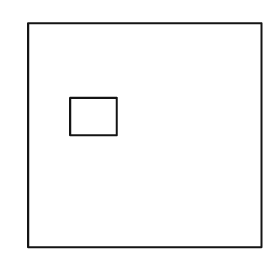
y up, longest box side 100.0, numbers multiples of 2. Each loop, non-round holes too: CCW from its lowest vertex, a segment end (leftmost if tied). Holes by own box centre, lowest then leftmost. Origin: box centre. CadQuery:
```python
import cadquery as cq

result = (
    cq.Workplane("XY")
    .moveTo(-50.0, -48.0)
    .lineTo(50.0, -48.0)
    .lineTo(50.0, 48.0)
    .lineTo(-50.0, 48.0)
    .close()
    .moveTo(-32.0, 0.0)
    .lineTo(-12.0, 0.0)
    .lineTo(-12.0, 16.0)
    .lineTo(-32.0, 16.0)
    .close()
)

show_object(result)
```